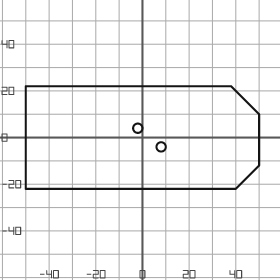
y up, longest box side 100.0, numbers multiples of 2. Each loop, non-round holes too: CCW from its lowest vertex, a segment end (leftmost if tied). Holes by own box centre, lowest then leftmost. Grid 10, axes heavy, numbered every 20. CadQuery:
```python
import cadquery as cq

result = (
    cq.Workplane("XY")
    .moveTo(-50.0, -22.0)
    .lineTo(40.0, -22.0)
    .lineTo(50.0, -12.0)
    .lineTo(50.0, 10.0)
    .lineTo(38.0, 22.0)
    .lineTo(-50.0, 22.0)
    .close()
    .moveTo(8.0, -4.0)
    .circle(2.0)
    .moveTo(-2.0, 4.0)
    .circle(2.0)
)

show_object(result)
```